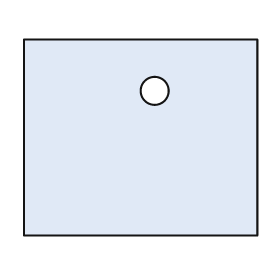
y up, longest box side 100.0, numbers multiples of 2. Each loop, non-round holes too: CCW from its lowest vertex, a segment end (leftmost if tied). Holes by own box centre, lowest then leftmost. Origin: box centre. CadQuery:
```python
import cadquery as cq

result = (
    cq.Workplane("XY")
    .moveTo(-50.0, -42.0)
    .lineTo(50.0, -42.0)
    .lineTo(50.0, 42.0)
    .lineTo(-50.0, 42.0)
    .close()
    .moveTo(6.0, 20.0)
    .circle(6.0)
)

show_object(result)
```